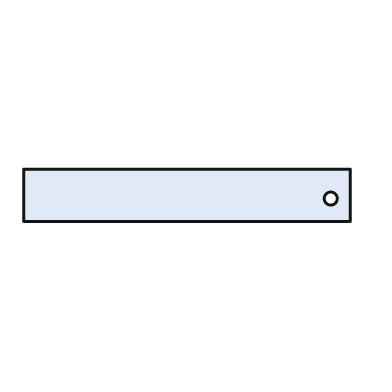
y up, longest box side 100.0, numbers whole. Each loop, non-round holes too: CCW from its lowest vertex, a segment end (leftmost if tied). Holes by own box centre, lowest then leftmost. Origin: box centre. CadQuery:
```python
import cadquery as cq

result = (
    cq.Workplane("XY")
    .moveTo(-50.0, -8.0)
    .lineTo(50.0, -8.0)
    .lineTo(50.0, 8.0)
    .lineTo(-50.0, 8.0)
    .close()
    .moveTo(44.0, -1.0)
    .circle(2.0)
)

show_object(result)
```